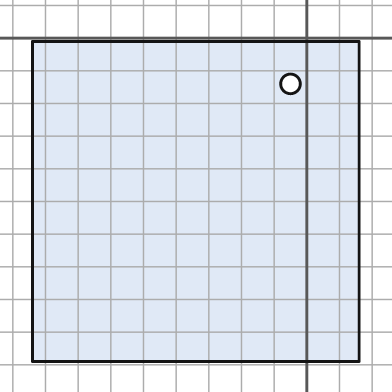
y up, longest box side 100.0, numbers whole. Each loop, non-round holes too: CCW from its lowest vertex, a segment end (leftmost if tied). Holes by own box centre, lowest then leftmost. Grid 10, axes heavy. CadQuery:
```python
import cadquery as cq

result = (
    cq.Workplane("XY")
    .moveTo(-84.0, -99.0)
    .lineTo(16.0, -99.0)
    .lineTo(16.0, -1.0)
    .lineTo(-84.0, -1.0)
    .close()
    .moveTo(-5.0, -14.0)
    .circle(3.0)
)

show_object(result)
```